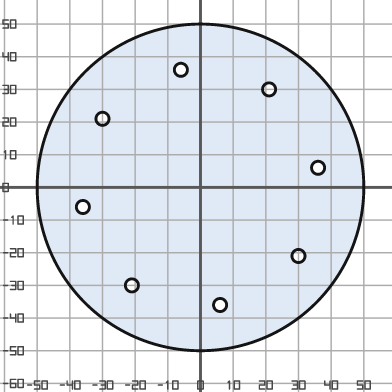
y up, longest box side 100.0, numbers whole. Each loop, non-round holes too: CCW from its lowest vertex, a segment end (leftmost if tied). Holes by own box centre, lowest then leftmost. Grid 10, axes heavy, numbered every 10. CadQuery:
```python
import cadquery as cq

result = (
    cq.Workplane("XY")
    .moveTo(0.0, 0.0)
    .circle(50.0)
    .moveTo(6.0, -36.0)
    .circle(2.0)
    .moveTo(-21.0, -30.0)
    .circle(2.0)
    .moveTo(30.0, -21.0)
    .circle(2.0)
    .moveTo(-36.0, -6.0)
    .circle(2.0)
    .moveTo(36.0, 6.0)
    .circle(2.0)
    .moveTo(-30.0, 21.0)
    .circle(2.0)
    .moveTo(21.0, 30.0)
    .circle(2.0)
    .moveTo(-6.0, 36.0)
    .circle(2.0)
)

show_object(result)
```